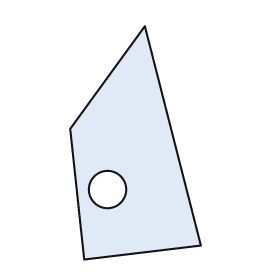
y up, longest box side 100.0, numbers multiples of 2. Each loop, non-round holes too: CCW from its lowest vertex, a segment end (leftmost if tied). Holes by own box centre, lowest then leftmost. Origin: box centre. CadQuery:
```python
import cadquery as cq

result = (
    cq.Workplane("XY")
    .moveTo(-22.0, -50.0)
    .lineTo(28.0, -44.0)
    .lineTo(4.0, 50.0)
    .lineTo(-28.0, 6.0)
    .close()
    .moveTo(-12.0, -20.0)
    .circle(8.0)
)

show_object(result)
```